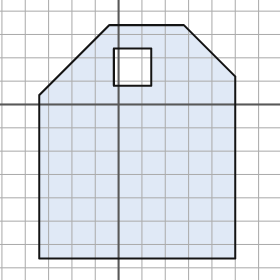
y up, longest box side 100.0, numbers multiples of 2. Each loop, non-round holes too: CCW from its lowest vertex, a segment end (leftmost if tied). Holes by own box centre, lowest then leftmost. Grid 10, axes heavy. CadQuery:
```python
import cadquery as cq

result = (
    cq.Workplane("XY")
    .moveTo(-34.0, -66.0)
    .lineTo(50.0, -66.0)
    .lineTo(50.0, 12.0)
    .lineTo(28.0, 34.0)
    .lineTo(-4.0, 34.0)
    .lineTo(-34.0, 4.0)
    .close()
    .moveTo(-2.0, 8.0)
    .lineTo(14.0, 8.0)
    .lineTo(14.0, 24.0)
    .lineTo(-2.0, 24.0)
    .close()
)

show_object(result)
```